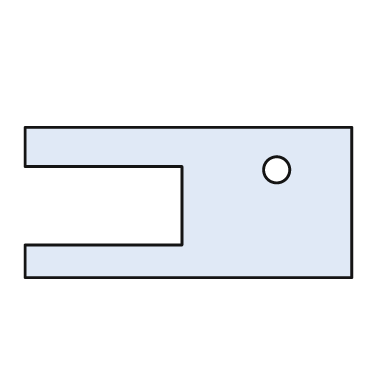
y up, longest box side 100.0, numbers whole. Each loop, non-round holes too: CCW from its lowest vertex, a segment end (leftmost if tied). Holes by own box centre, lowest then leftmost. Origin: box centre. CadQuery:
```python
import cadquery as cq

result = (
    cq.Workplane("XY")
    .moveTo(-50.0, -23.0)
    .lineTo(50.0, -23.0)
    .lineTo(50.0, 23.0)
    .lineTo(-50.0, 23.0)
    .lineTo(-50.0, 11.0)
    .lineTo(-2.0, 11.0)
    .lineTo(-2.0, -13.0)
    .lineTo(-50.0, -13.0)
    .close()
    .moveTo(27.0, 10.0)
    .circle(4.0)
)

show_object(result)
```